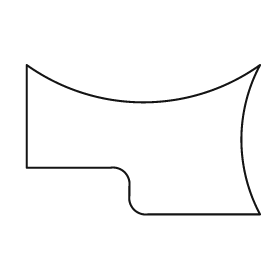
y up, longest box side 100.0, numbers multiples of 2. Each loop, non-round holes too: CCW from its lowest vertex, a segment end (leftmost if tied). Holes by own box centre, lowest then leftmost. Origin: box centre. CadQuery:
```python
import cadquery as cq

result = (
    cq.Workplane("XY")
    .moveTo(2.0, -32.0)
    .lineTo(50.0, -32.0)
    .threePointArc((42.0, 0.0), (50.0, 32.0))
    .threePointArc((0.0, 16.0), (-50.0, 32.0))
    .lineTo(-50.0, -12.0)
    .lineTo(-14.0, -12.0)
    .threePointArc((-8.0, -14.0), (-6.0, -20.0))
    .lineTo(-6.0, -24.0)
    .threePointArc((-4.0, -30.0), (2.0, -32.0))
    .close()
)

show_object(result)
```